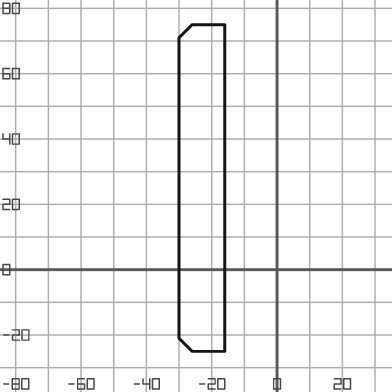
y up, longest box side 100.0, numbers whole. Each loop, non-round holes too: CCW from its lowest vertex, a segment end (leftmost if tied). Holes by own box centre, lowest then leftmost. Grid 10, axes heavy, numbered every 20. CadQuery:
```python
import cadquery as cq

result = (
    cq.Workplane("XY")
    .moveTo(-26.0, -25.0)
    .lineTo(-16.0, -25.0)
    .lineTo(-16.0, 75.0)
    .lineTo(-26.0, 75.0)
    .lineTo(-30.0, 71.0)
    .lineTo(-30.0, -21.0)
    .close()
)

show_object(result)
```